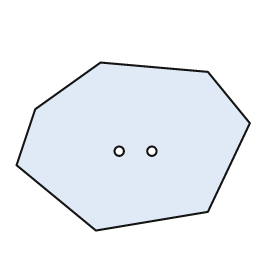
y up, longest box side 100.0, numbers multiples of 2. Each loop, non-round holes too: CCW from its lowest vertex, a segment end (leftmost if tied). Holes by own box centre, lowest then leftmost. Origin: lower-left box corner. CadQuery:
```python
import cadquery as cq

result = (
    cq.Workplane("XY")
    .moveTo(34.0, 0.0)
    .lineTo(82.0, 8.0)
    .lineTo(100.0, 46.0)
    .lineTo(82.0, 68.0)
    .lineTo(36.0, 72.0)
    .lineTo(8.0, 52.0)
    .lineTo(0.0, 28.0)
    .close()
    .moveTo(44.0, 34.0)
    .circle(2.0)
    .moveTo(58.0, 34.0)
    .circle(2.0)
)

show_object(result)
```